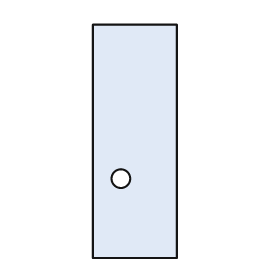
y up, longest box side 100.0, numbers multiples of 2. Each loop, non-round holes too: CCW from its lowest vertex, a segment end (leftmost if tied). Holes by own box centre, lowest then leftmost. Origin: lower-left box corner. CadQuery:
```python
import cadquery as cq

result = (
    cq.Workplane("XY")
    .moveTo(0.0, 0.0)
    .lineTo(36.0, 0.0)
    .lineTo(36.0, 100.0)
    .lineTo(0.0, 100.0)
    .close()
    .moveTo(12.0, 34.0)
    .circle(4.0)
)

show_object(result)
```